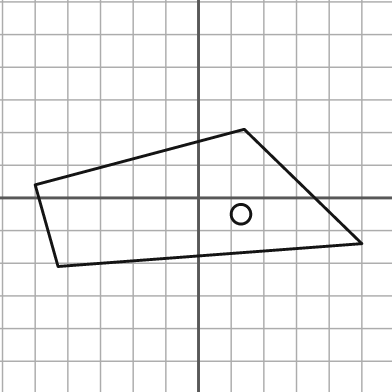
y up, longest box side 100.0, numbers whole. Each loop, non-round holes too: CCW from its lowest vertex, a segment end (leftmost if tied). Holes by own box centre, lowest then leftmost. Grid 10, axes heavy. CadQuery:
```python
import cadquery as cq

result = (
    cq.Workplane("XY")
    .moveTo(-43.0, -21.0)
    .lineTo(50.0, -14.0)
    .lineTo(14.0, 21.0)
    .lineTo(-50.0, 4.0)
    .close()
    .moveTo(13.0, -5.0)
    .circle(3.0)
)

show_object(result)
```